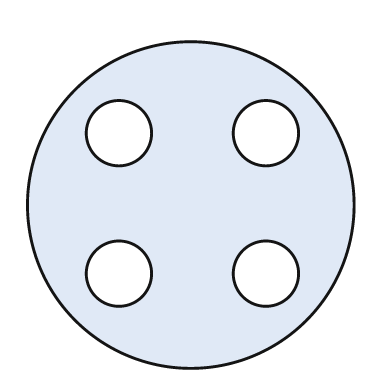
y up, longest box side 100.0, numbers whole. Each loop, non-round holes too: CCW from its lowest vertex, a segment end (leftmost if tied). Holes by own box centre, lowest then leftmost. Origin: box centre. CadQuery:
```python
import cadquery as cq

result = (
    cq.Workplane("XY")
    .moveTo(0.0, 0.0)
    .circle(50.0)
    .moveTo(-22.0, -21.0)
    .circle(10.0)
    .moveTo(23.0, -21.0)
    .circle(10.0)
    .moveTo(-22.0, 22.0)
    .circle(10.0)
    .moveTo(23.0, 22.0)
    .circle(10.0)
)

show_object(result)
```